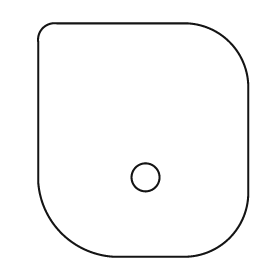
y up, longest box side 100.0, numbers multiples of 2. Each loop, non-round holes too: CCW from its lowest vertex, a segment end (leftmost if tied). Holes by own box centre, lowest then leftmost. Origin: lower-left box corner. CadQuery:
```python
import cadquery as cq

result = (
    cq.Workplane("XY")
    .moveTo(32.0, 0.0)
    .lineTo(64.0, 0.0)
    .threePointArc((82.0, 8.0), (90.0, 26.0))
    .lineTo(90.0, 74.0)
    .threePointArc((82.0, 92.0), (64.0, 100.0))
    .lineTo(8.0, 100.0)
    .threePointArc((2.0, 98.0), (0.0, 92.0))
    .lineTo(0.0, 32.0)
    .threePointArc((10.0, 10.0), (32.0, 0.0))
    .close()
    .moveTo(46.0, 34.0)
    .circle(6.0)
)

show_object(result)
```